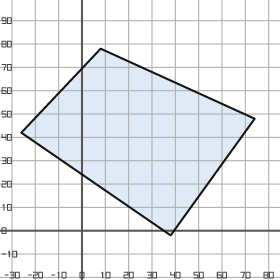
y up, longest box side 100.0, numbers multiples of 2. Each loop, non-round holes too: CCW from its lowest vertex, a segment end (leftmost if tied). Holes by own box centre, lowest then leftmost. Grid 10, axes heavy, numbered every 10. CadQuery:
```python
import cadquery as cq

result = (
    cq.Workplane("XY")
    .moveTo(38.0, -2.0)
    .lineTo(74.0, 48.0)
    .lineTo(8.0, 78.0)
    .lineTo(-26.0, 42.0)
    .close()
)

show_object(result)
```